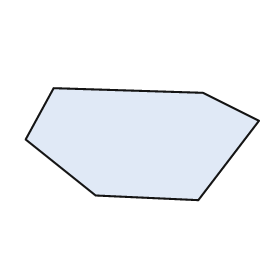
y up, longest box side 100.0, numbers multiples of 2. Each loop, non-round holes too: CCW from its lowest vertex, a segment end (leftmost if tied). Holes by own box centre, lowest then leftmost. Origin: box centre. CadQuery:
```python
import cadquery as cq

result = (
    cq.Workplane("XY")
    .moveTo(24.0, -24.0)
    .lineTo(50.0, 10.0)
    .lineTo(26.0, 22.0)
    .lineTo(-38.0, 24.0)
    .lineTo(-50.0, 2.0)
    .lineTo(-20.0, -22.0)
    .close()
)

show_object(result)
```